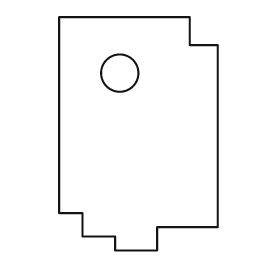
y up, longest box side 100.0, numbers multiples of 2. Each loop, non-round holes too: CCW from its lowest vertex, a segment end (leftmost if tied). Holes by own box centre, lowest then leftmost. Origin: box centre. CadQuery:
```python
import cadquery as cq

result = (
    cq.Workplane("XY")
    .moveTo(-10.0, -50.0)
    .lineTo(8.0, -50.0)
    .lineTo(8.0, -40.0)
    .lineTo(34.0, -40.0)
    .lineTo(34.0, 38.0)
    .lineTo(22.0, 38.0)
    .lineTo(22.0, 50.0)
    .lineTo(-34.0, 50.0)
    .lineTo(-34.0, -34.0)
    .lineTo(-24.0, -34.0)
    .lineTo(-24.0, -44.0)
    .lineTo(-10.0, -44.0)
    .close()
    .moveTo(-8.0, 26.0)
    .circle(8.0)
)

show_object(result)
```